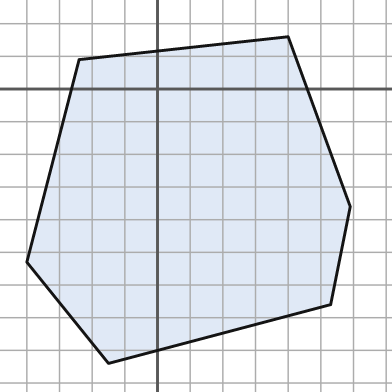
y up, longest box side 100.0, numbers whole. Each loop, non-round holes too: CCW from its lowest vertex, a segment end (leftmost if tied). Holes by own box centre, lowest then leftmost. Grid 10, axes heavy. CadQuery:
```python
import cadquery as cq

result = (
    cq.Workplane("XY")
    .moveTo(-15.0, -84.0)
    .lineTo(53.0, -66.0)
    .lineTo(59.0, -36.0)
    .lineTo(40.0, 16.0)
    .lineTo(-24.0, 9.0)
    .lineTo(-40.0, -53.0)
    .close()
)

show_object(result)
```